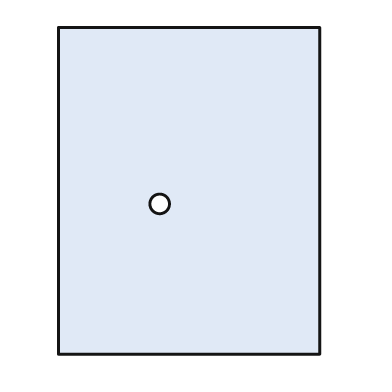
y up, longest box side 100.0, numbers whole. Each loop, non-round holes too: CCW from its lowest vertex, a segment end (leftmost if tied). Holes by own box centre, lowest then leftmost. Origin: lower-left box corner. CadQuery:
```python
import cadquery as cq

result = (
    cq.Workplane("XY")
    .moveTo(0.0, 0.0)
    .lineTo(80.0, 0.0)
    .lineTo(80.0, 100.0)
    .lineTo(0.0, 100.0)
    .close()
    .moveTo(31.0, 46.0)
    .circle(3.0)
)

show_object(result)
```